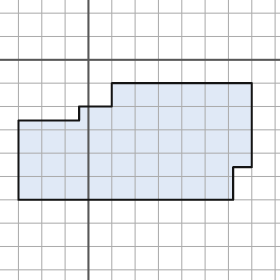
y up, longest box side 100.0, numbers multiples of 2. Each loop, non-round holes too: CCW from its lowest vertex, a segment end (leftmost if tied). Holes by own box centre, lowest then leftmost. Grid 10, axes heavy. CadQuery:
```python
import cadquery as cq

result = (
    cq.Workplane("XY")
    .moveTo(-30.0, -60.0)
    .lineTo(62.0, -60.0)
    .lineTo(62.0, -46.0)
    .lineTo(70.0, -46.0)
    .lineTo(70.0, -10.0)
    .lineTo(10.0, -10.0)
    .lineTo(10.0, -20.0)
    .lineTo(-4.0, -20.0)
    .lineTo(-4.0, -26.0)
    .lineTo(-30.0, -26.0)
    .close()
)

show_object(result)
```